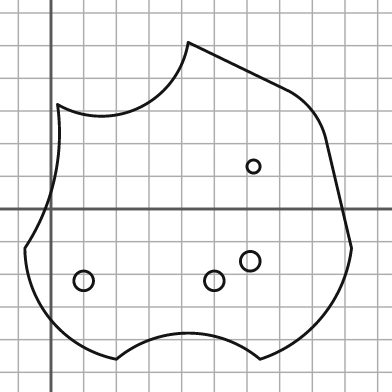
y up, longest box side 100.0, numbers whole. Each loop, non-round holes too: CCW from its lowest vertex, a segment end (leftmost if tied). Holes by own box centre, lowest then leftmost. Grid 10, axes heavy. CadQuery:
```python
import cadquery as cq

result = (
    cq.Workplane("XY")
    .moveTo(20.0, -46.0)
    .threePointArc((42.0, -38.0), (64.0, -46.0))
    .threePointArc((83.0, -33.0), (92.0, -12.0))
    .lineTo(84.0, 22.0)
    .threePointArc((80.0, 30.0), (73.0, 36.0))
    .lineTo(42.0, 51.0)
    .threePointArc((27.0, 31.0), (2.0, 32.0))
    .threePointArc((1.0, 9.0), (-8.0, -12.0))
    .threePointArc((0.0, -34.0), (20.0, -46.0))
    .close()
    .moveTo(10.0, -22.0)
    .circle(3.0)
    .moveTo(50.0, -22.0)
    .circle(3.0)
    .moveTo(61.0, -16.0)
    .circle(3.0)
    .moveTo(62.0, 13.0)
    .circle(2.0)
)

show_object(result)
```